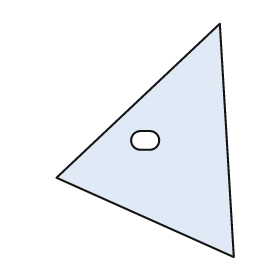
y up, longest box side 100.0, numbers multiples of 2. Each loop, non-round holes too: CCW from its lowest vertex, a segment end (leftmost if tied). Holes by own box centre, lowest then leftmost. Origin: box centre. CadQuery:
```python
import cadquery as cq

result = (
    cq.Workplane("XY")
    .moveTo(38.0, -50.0)
    .lineTo(32.0, 50.0)
    .lineTo(-38.0, -16.0)
    .close()
    .moveTo(-2.0, -4.0)
    .lineTo(2.0, -4.0)
    .threePointArc((6.0, 0.0), (2.0, 4.0))
    .lineTo(-2.0, 4.0)
    .threePointArc((-6.0, 0.0), (-2.0, -4.0))
    .close()
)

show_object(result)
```